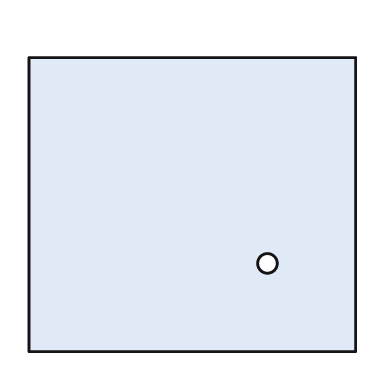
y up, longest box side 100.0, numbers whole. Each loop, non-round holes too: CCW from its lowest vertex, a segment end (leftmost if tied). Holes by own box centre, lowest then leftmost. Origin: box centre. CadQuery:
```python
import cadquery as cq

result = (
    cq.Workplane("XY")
    .moveTo(-50.0, -45.0)
    .lineTo(50.0, -45.0)
    .lineTo(50.0, 45.0)
    .lineTo(-50.0, 45.0)
    .close()
    .moveTo(23.0, -18.0)
    .circle(3.0)
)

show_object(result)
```